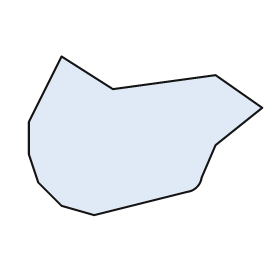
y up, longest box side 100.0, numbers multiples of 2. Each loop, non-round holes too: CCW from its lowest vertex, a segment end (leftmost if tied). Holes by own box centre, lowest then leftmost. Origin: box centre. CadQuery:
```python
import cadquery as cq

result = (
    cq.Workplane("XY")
    .moveTo(-22.0, -34.0)
    .lineTo(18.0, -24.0)
    .threePointArc((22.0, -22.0), (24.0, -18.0))
    .lineTo(30.0, -4.0)
    .lineTo(50.0, 12.0)
    .lineTo(30.0, 26.0)
    .lineTo(-14.0, 20.0)
    .lineTo(-36.0, 34.0)
    .lineTo(-50.0, 6.0)
    .lineTo(-50.0, -8.0)
    .lineTo(-46.0, -20.0)
    .lineTo(-36.0, -30.0)
    .close()
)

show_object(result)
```